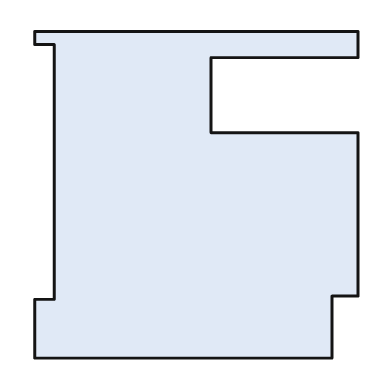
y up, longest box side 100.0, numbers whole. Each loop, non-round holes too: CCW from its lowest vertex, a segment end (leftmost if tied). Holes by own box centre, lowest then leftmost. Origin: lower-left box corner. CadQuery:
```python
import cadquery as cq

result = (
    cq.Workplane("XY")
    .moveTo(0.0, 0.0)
    .lineTo(91.0, 0.0)
    .lineTo(91.0, 19.0)
    .lineTo(99.0, 19.0)
    .lineTo(99.0, 69.0)
    .lineTo(54.0, 69.0)
    .lineTo(54.0, 92.0)
    .lineTo(99.0, 92.0)
    .lineTo(99.0, 100.0)
    .lineTo(0.0, 100.0)
    .lineTo(0.0, 96.0)
    .lineTo(6.0, 96.0)
    .lineTo(6.0, 18.0)
    .lineTo(0.0, 18.0)
    .close()
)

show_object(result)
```